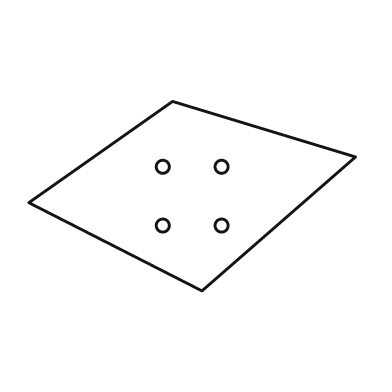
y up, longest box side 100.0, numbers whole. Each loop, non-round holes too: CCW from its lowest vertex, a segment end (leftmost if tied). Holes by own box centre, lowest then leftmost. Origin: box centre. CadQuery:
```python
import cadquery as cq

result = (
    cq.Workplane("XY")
    .moveTo(3.0, -29.0)
    .lineTo(50.0, 12.0)
    .lineTo(-6.0, 29.0)
    .lineTo(-50.0, -2.0)
    .close()
    .moveTo(-9.0, -9.0)
    .circle(2.0)
    .moveTo(9.0, -9.0)
    .circle(2.0)
    .moveTo(-9.0, 9.0)
    .circle(2.0)
    .moveTo(9.0, 9.0)
    .circle(2.0)
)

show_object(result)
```